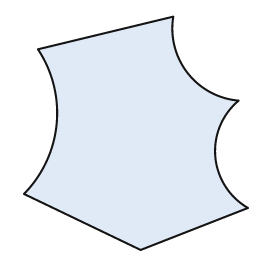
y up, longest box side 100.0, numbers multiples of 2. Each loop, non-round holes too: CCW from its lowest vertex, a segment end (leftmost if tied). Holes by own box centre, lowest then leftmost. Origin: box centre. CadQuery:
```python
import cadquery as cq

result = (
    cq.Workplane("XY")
    .moveTo(2.0, -50.0)
    .lineTo(48.0, -32.0)
    .threePointArc((34.0, -10.0), (44.0, 14.0))
    .threePointArc((22.0, 26.0), (16.0, 50.0))
    .lineTo(-42.0, 36.0)
    .threePointArc((-34.0, 4.0), (-48.0, -26.0))
    .close()
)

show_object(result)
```